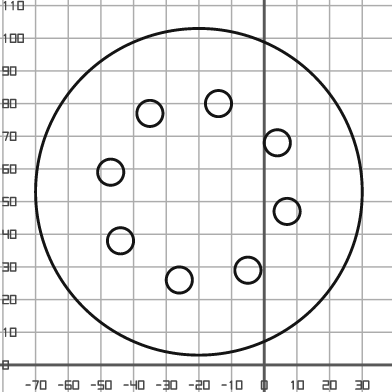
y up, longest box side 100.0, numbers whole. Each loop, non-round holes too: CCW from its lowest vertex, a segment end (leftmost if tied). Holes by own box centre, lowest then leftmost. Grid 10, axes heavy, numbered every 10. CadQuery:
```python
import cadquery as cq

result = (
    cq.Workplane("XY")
    .moveTo(-20.0, 53.0)
    .circle(50.0)
    .moveTo(-26.0, 26.0)
    .circle(4.0)
    .moveTo(-5.0, 29.0)
    .circle(4.0)
    .moveTo(-44.0, 38.0)
    .circle(4.0)
    .moveTo(7.0, 47.0)
    .circle(4.0)
    .moveTo(-47.0, 59.0)
    .circle(4.0)
    .moveTo(4.0, 68.0)
    .circle(4.0)
    .moveTo(-35.0, 77.0)
    .circle(4.0)
    .moveTo(-14.0, 80.0)
    .circle(4.0)
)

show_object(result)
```